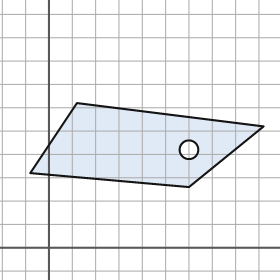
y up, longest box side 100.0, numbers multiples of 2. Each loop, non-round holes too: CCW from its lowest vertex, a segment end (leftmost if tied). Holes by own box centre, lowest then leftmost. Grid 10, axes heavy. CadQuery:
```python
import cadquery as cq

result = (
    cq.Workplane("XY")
    .moveTo(60.0, 26.0)
    .lineTo(92.0, 52.0)
    .lineTo(12.0, 62.0)
    .lineTo(-8.0, 32.0)
    .close()
    .moveTo(60.0, 42.0)
    .circle(4.0)
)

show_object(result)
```